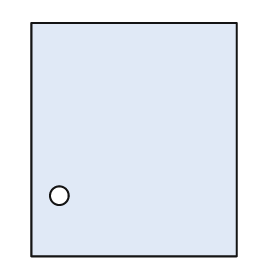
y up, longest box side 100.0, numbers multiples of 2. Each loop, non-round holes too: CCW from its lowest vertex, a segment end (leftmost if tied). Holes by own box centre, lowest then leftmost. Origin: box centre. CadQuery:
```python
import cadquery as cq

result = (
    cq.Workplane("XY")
    .moveTo(-44.0, -50.0)
    .lineTo(44.0, -50.0)
    .lineTo(44.0, 50.0)
    .lineTo(-44.0, 50.0)
    .close()
    .moveTo(-32.0, -24.0)
    .circle(4.0)
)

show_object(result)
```